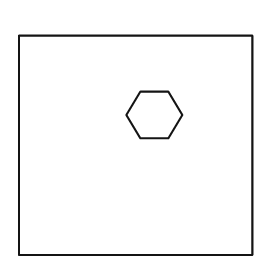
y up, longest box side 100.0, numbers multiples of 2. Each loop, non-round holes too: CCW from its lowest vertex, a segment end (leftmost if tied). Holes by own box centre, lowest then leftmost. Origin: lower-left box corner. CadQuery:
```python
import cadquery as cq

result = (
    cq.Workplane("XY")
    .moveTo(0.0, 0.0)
    .lineTo(100.0, 0.0)
    .lineTo(100.0, 94.0)
    .lineTo(0.0, 94.0)
    .close()
    .moveTo(52.0, 50.0)
    .lineTo(64.0, 50.0)
    .lineTo(70.0, 60.0)
    .lineTo(64.0, 70.0)
    .lineTo(52.0, 70.0)
    .lineTo(46.0, 60.0)
    .close()
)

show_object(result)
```